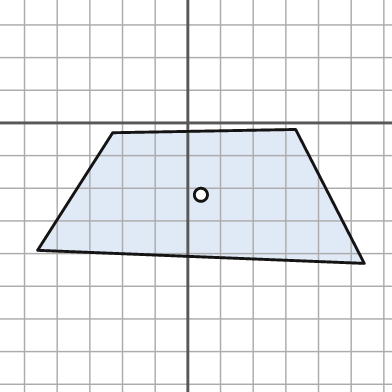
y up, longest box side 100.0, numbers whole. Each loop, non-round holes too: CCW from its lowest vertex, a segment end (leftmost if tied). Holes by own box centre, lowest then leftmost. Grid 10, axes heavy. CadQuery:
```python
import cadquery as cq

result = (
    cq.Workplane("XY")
    .moveTo(54.0, -43.0)
    .lineTo(33.0, -2.0)
    .lineTo(-23.0, -3.0)
    .lineTo(-46.0, -39.0)
    .close()
    .moveTo(4.0, -22.0)
    .circle(2.0)
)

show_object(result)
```